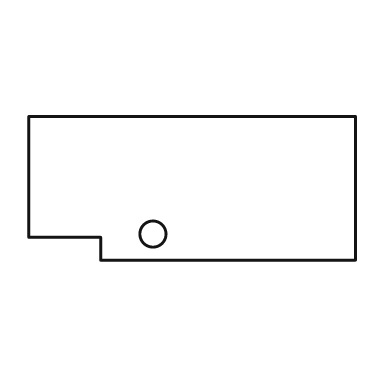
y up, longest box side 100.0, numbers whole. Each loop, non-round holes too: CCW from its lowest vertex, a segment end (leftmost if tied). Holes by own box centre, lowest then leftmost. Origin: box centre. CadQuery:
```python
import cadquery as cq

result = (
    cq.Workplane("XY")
    .moveTo(-28.0, -22.0)
    .lineTo(50.0, -22.0)
    .lineTo(50.0, 22.0)
    .lineTo(-50.0, 22.0)
    .lineTo(-50.0, -15.0)
    .lineTo(-28.0, -15.0)
    .close()
    .moveTo(-12.0, -14.0)
    .circle(4.0)
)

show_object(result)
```